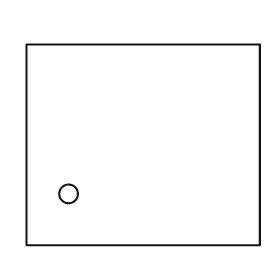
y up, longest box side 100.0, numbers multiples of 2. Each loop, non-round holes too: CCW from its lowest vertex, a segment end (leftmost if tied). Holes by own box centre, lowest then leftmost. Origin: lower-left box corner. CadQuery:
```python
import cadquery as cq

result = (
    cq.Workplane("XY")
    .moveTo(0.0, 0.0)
    .lineTo(100.0, 0.0)
    .lineTo(100.0, 86.0)
    .lineTo(0.0, 86.0)
    .close()
    .moveTo(18.0, 22.0)
    .circle(4.0)
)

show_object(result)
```